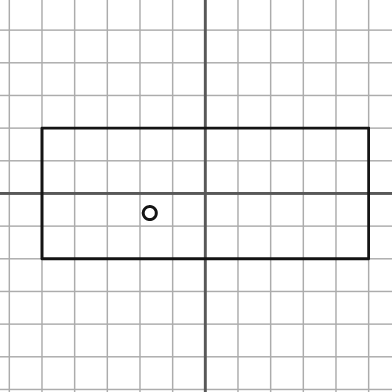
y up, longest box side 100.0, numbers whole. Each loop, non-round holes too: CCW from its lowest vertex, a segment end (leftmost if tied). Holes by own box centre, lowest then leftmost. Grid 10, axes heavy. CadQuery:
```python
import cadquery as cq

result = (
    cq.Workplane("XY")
    .moveTo(-50.0, -20.0)
    .lineTo(50.0, -20.0)
    .lineTo(50.0, 20.0)
    .lineTo(-50.0, 20.0)
    .close()
    .moveTo(-17.0, -6.0)
    .circle(2.0)
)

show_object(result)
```